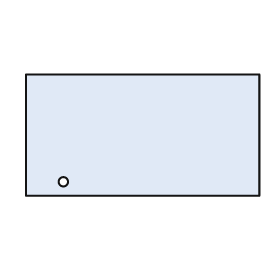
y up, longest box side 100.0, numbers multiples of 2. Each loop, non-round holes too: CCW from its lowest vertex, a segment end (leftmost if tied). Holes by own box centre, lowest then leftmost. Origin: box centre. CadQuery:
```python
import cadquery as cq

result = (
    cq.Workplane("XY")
    .moveTo(-50.0, -26.0)
    .lineTo(50.0, -26.0)
    .lineTo(50.0, 26.0)
    .lineTo(-50.0, 26.0)
    .close()
    .moveTo(-34.0, -20.0)
    .circle(2.0)
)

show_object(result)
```